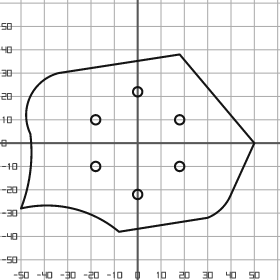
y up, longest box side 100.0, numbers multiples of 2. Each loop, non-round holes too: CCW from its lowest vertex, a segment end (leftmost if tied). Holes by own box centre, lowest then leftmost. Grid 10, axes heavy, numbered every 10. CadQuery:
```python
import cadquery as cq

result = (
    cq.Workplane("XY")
    .moveTo(-8.0, -38.0)
    .lineTo(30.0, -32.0)
    .threePointArc((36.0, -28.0), (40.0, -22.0))
    .lineTo(50.0, 0.0)
    .lineTo(18.0, 38.0)
    .lineTo(-34.0, 30.0)
    .threePointArc((-46.0, 20.0), (-46.0, 4.0))
    .threePointArc((-46.0, -12.0), (-50.0, -28.0))
    .threePointArc((-28.0, -28.0), (-8.0, -38.0))
    .close()
    .moveTo(0.0, -22.0)
    .circle(2.0)
    .moveTo(-18.0, -10.0)
    .circle(2.0)
    .moveTo(18.0, -10.0)
    .circle(2.0)
    .moveTo(-18.0, 10.0)
    .circle(2.0)
    .moveTo(18.0, 10.0)
    .circle(2.0)
    .moveTo(0.0, 22.0)
    .circle(2.0)
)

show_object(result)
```